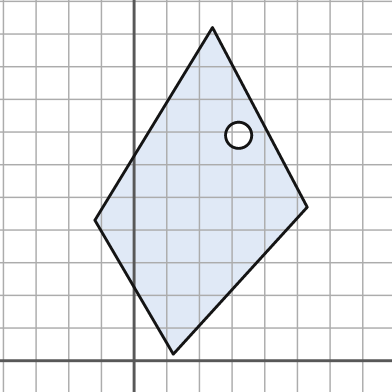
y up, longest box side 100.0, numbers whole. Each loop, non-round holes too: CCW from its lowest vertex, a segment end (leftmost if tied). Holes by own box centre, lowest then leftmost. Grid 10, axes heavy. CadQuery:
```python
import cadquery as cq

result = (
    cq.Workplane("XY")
    .moveTo(12.0, 2.0)
    .lineTo(53.0, 47.0)
    .lineTo(24.0, 102.0)
    .lineTo(-12.0, 43.0)
    .close()
    .moveTo(32.0, 69.0)
    .circle(4.0)
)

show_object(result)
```